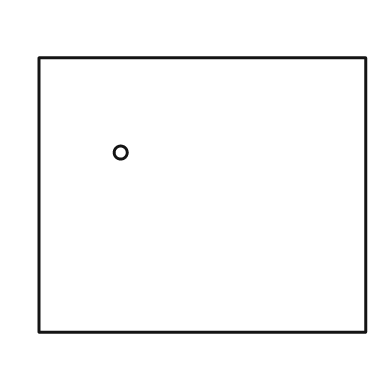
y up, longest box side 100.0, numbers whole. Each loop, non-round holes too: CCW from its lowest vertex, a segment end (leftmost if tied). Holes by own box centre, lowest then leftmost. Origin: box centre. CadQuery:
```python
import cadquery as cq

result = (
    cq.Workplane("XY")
    .moveTo(-50.0, -42.0)
    .lineTo(50.0, -42.0)
    .lineTo(50.0, 42.0)
    .lineTo(-50.0, 42.0)
    .close()
    .moveTo(-25.0, 13.0)
    .circle(2.0)
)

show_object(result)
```